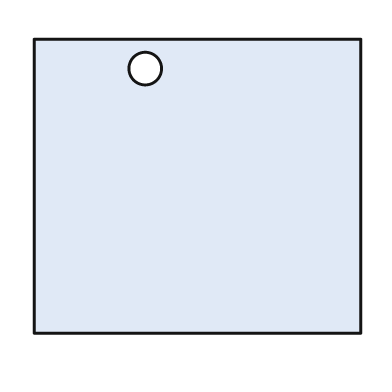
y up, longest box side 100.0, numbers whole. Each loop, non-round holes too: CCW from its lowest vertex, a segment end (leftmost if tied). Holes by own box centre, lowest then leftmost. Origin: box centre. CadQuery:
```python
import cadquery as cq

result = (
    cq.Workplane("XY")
    .moveTo(-50.0, -45.0)
    .lineTo(50.0, -45.0)
    .lineTo(50.0, 45.0)
    .lineTo(-50.0, 45.0)
    .close()
    .moveTo(-16.0, 36.0)
    .circle(5.0)
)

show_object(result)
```